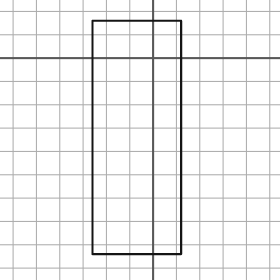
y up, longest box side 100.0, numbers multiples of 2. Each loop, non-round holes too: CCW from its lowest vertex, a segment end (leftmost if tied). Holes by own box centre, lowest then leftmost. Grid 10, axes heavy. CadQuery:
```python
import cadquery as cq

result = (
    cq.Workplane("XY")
    .moveTo(-26.0, -84.0)
    .lineTo(12.0, -84.0)
    .lineTo(12.0, 16.0)
    .lineTo(-26.0, 16.0)
    .close()
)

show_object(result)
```